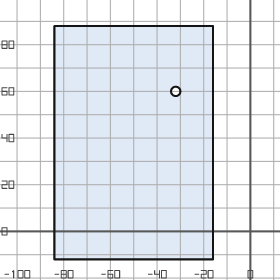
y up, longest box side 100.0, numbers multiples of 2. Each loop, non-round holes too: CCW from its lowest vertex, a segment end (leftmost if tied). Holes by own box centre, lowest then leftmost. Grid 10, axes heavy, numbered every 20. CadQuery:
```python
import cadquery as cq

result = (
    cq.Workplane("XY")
    .moveTo(-84.0, -12.0)
    .lineTo(-16.0, -12.0)
    .lineTo(-16.0, 88.0)
    .lineTo(-84.0, 88.0)
    .close()
    .moveTo(-32.0, 60.0)
    .circle(2.0)
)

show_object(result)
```